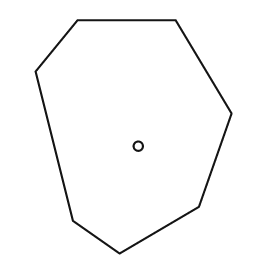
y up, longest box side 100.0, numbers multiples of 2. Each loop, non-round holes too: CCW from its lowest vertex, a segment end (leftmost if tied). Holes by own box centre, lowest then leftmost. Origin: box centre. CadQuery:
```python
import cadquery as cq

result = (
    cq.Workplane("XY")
    .moveTo(-6.0, -50.0)
    .lineTo(28.0, -30.0)
    .lineTo(42.0, 10.0)
    .lineTo(18.0, 50.0)
    .lineTo(-24.0, 50.0)
    .lineTo(-42.0, 28.0)
    .lineTo(-26.0, -36.0)
    .close()
    .moveTo(2.0, -4.0)
    .circle(2.0)
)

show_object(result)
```